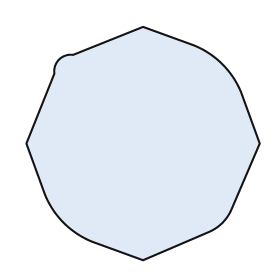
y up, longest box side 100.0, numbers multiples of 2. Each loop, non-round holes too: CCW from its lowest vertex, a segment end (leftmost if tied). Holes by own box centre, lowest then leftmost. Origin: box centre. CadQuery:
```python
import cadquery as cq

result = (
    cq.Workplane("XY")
    .moveTo(0.0, -50.0)
    .lineTo(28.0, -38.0)
    .threePointArc((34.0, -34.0), (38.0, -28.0))
    .lineTo(50.0, 0.0)
    .lineTo(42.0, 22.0)
    .threePointArc((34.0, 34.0), (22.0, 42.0))
    .lineTo(0.0, 50.0)
    .lineTo(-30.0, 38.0)
    .threePointArc((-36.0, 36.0), (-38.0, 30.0))
    .lineTo(-50.0, 0.0)
    .lineTo(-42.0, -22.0)
    .threePointArc((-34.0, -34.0), (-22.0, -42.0))
    .close()
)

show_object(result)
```